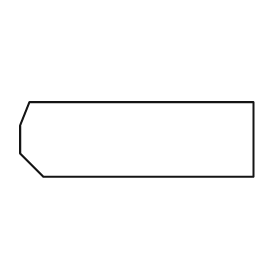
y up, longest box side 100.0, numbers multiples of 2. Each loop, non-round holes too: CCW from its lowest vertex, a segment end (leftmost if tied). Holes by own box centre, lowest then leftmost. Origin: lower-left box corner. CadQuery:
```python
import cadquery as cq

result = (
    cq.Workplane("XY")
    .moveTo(10.0, 0.0)
    .lineTo(100.0, 0.0)
    .lineTo(100.0, 32.0)
    .lineTo(4.0, 32.0)
    .lineTo(0.0, 22.0)
    .lineTo(0.0, 10.0)
    .close()
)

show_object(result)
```